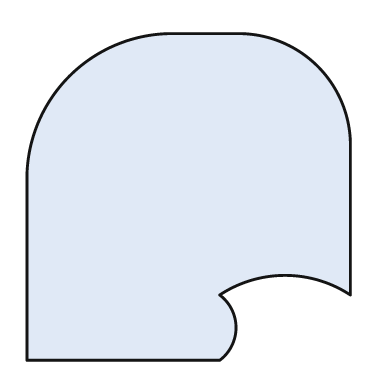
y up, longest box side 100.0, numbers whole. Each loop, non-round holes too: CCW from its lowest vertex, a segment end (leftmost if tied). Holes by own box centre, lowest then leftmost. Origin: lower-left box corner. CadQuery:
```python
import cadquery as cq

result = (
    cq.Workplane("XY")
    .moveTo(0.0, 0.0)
    .lineTo(59.0, 0.0)
    .threePointArc((64.0, 10.0), (59.0, 20.0))
    .threePointArc((79.0, 26.0), (99.0, 20.0))
    .lineTo(99.0, 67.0)
    .threePointArc((89.0, 90.0), (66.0, 100.0))
    .lineTo(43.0, 100.0)
    .threePointArc((13.0, 87.0), (0.0, 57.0))
    .close()
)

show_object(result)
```